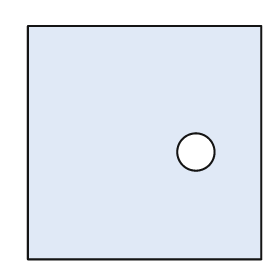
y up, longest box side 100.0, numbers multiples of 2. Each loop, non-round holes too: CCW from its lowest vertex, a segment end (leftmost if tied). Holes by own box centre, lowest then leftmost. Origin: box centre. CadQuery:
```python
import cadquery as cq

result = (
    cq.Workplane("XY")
    .moveTo(-50.0, -50.0)
    .lineTo(50.0, -50.0)
    .lineTo(50.0, 50.0)
    .lineTo(-50.0, 50.0)
    .close()
    .moveTo(22.0, -4.0)
    .circle(8.0)
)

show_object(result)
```